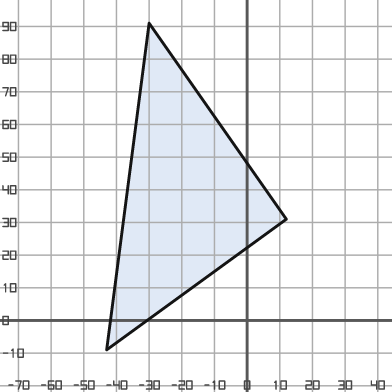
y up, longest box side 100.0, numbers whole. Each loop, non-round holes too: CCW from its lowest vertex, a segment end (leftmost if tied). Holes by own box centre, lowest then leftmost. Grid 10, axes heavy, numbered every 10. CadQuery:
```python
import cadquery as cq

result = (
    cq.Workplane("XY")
    .moveTo(-43.0, -9.0)
    .lineTo(12.0, 31.0)
    .lineTo(-30.0, 91.0)
    .close()
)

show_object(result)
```